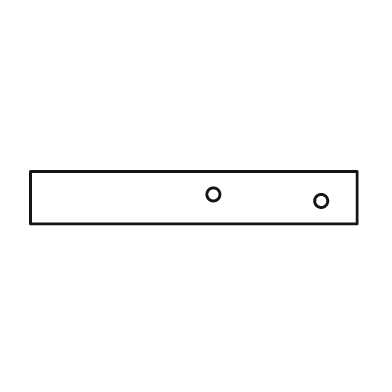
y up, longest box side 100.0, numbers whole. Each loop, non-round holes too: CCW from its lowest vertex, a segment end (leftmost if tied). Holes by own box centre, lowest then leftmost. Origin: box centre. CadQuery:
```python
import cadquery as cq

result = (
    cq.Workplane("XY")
    .moveTo(-50.0, -8.0)
    .lineTo(50.0, -8.0)
    .lineTo(50.0, 8.0)
    .lineTo(-50.0, 8.0)
    .close()
    .moveTo(39.0, -1.0)
    .circle(2.0)
    .moveTo(6.0, 1.0)
    .circle(2.0)
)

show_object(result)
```